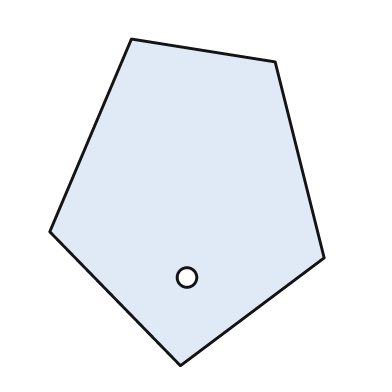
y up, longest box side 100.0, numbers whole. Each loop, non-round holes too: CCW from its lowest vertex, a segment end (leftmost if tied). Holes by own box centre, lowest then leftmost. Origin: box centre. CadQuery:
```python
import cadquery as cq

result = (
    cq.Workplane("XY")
    .moveTo(-2.0, -50.0)
    .lineTo(42.0, -17.0)
    .lineTo(27.0, 43.0)
    .lineTo(-17.0, 50.0)
    .lineTo(-42.0, -9.0)
    .close()
    .moveTo(0.0, -23.0)
    .circle(3.0)
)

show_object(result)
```